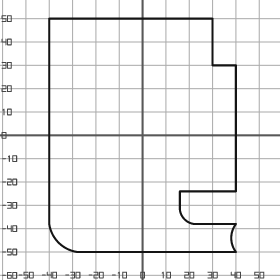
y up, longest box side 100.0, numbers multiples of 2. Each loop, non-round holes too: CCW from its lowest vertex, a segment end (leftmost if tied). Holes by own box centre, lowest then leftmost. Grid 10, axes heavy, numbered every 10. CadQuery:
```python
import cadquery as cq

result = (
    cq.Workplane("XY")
    .moveTo(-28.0, -50.0)
    .lineTo(40.0, -50.0)
    .threePointArc((38.0, -44.0), (40.0, -38.0))
    .lineTo(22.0, -38.0)
    .threePointArc((18.0, -36.0), (16.0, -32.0))
    .lineTo(16.0, -24.0)
    .lineTo(40.0, -24.0)
    .lineTo(40.0, 30.0)
    .lineTo(30.0, 30.0)
    .lineTo(30.0, 50.0)
    .lineTo(-40.0, 50.0)
    .lineTo(-40.0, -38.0)
    .threePointArc((-36.0, -46.0), (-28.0, -50.0))
    .close()
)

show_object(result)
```